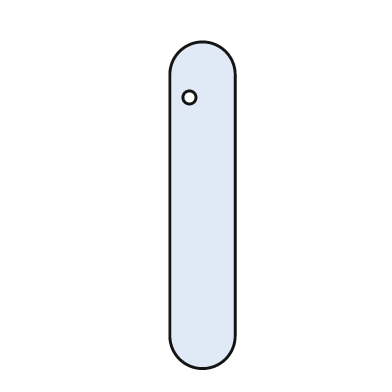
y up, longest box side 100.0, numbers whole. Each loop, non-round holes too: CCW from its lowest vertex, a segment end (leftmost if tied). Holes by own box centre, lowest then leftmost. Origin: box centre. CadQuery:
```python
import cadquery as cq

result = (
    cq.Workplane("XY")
    .moveTo(-10.0, -40.0)
    .threePointArc((0.0, -50.0), (10.0, -40.0))
    .lineTo(10.0, 40.0)
    .threePointArc((0.0, 50.0), (-10.0, 40.0))
    .close()
    .moveTo(-4.0, 33.0)
    .circle(2.0)
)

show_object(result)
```